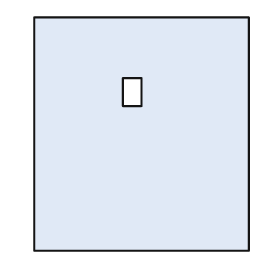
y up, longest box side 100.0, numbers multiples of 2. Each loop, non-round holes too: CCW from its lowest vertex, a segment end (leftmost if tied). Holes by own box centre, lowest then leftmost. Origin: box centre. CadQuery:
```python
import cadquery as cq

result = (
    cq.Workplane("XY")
    .moveTo(-46.0, -50.0)
    .lineTo(46.0, -50.0)
    .lineTo(46.0, 50.0)
    .lineTo(-46.0, 50.0)
    .close()
    .moveTo(-8.0, 12.0)
    .lineTo(0.0, 12.0)
    .lineTo(0.0, 24.0)
    .lineTo(-8.0, 24.0)
    .close()
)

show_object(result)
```